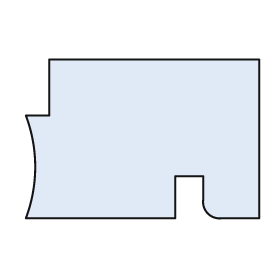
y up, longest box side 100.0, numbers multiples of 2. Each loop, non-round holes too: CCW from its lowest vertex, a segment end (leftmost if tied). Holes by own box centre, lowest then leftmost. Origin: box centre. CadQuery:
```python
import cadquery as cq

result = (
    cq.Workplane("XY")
    .moveTo(-50.0, -34.0)
    .lineTo(14.0, -34.0)
    .lineTo(14.0, -16.0)
    .lineTo(26.0, -16.0)
    .lineTo(26.0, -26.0)
    .threePointArc((28.0, -32.0), (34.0, -34.0))
    .lineTo(50.0, -34.0)
    .lineTo(50.0, 34.0)
    .lineTo(-40.0, 34.0)
    .lineTo(-40.0, 10.0)
    .lineTo(-50.0, 10.0)
    .threePointArc((-46.0, -12.0), (-50.0, -34.0))
    .close()
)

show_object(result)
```